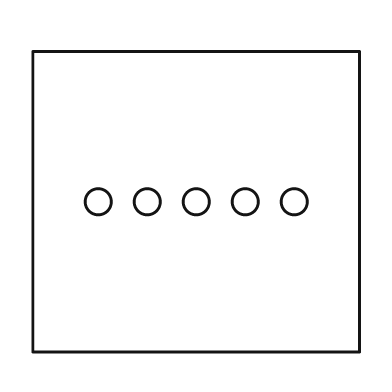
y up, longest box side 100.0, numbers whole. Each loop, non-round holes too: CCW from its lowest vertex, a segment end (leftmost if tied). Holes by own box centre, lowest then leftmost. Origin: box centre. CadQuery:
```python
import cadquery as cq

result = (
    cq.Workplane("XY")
    .moveTo(-50.0, -46.0)
    .lineTo(50.0, -46.0)
    .lineTo(50.0, 46.0)
    .lineTo(-50.0, 46.0)
    .close()
    .moveTo(-30.0, 0.0)
    .circle(4.0)
    .moveTo(-15.0, 0.0)
    .circle(4.0)
    .moveTo(0.0, 0.0)
    .circle(4.0)
    .moveTo(15.0, 0.0)
    .circle(4.0)
    .moveTo(30.0, 0.0)
    .circle(4.0)
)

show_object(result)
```